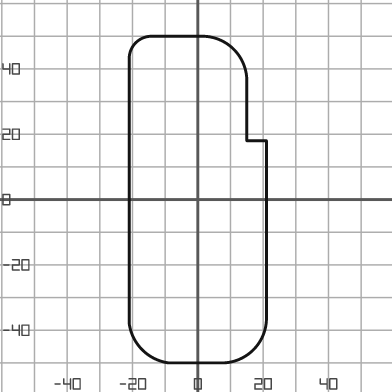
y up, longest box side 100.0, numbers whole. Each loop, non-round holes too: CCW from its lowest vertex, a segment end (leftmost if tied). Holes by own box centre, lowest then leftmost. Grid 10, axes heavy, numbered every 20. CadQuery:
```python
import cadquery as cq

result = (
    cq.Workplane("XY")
    .moveTo(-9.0, -50.0)
    .lineTo(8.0, -50.0)
    .threePointArc((17.0, -46.0), (21.0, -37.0))
    .lineTo(21.0, 18.0)
    .lineTo(15.0, 18.0)
    .lineTo(15.0, 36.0)
    .threePointArc((11.0, 46.0), (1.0, 50.0))
    .lineTo(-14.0, 50.0)
    .threePointArc((-19.0, 48.0), (-21.0, 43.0))
    .lineTo(-21.0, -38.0)
    .threePointArc((-17.0, -46.0), (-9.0, -50.0))
    .close()
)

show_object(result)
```